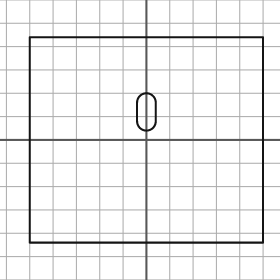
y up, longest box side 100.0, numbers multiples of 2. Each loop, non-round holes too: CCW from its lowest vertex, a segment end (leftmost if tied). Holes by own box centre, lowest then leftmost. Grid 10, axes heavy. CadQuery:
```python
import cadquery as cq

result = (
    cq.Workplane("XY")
    .moveTo(-50.0, -44.0)
    .lineTo(50.0, -44.0)
    .lineTo(50.0, 44.0)
    .lineTo(-50.0, 44.0)
    .close()
    .moveTo(-4.0, 8.0)
    .threePointArc((0.0, 4.0), (4.0, 8.0))
    .lineTo(4.0, 16.0)
    .threePointArc((0.0, 20.0), (-4.0, 16.0))
    .close()
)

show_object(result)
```